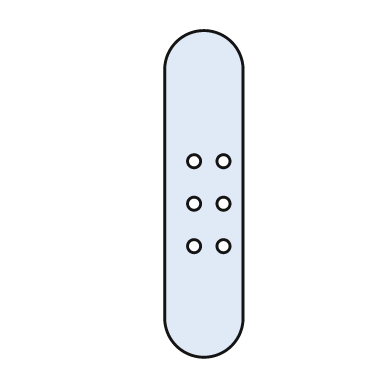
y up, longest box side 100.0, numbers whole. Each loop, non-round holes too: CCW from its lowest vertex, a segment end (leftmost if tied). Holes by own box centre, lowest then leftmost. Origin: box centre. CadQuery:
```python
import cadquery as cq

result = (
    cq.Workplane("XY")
    .moveTo(-12.0, -38.0)
    .threePointArc((0.0, -50.0), (12.0, -38.0))
    .lineTo(12.0, 38.0)
    .threePointArc((0.0, 50.0), (-12.0, 38.0))
    .close()
    .moveTo(-3.0, -16.0)
    .circle(2.0)
    .moveTo(6.0, -16.0)
    .circle(2.0)
    .moveTo(-3.0, -3.0)
    .circle(2.0)
    .moveTo(6.0, -3.0)
    .circle(2.0)
    .moveTo(-3.0, 10.0)
    .circle(2.0)
    .moveTo(6.0, 10.0)
    .circle(2.0)
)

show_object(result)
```